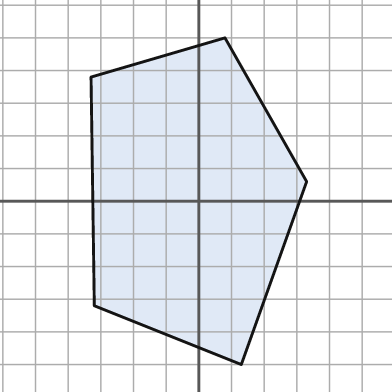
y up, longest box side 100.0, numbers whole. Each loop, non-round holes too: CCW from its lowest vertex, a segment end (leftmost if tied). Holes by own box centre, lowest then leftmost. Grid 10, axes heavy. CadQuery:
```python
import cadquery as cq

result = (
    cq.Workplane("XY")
    .moveTo(13.0, -50.0)
    .lineTo(33.0, 6.0)
    .lineTo(8.0, 50.0)
    .lineTo(-33.0, 38.0)
    .lineTo(-32.0, -32.0)
    .close()
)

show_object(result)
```